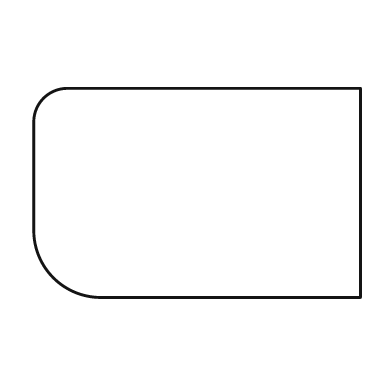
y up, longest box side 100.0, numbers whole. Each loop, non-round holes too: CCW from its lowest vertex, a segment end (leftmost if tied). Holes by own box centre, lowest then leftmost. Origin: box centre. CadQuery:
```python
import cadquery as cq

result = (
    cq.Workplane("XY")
    .moveTo(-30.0, -32.0)
    .lineTo(50.0, -32.0)
    .lineTo(50.0, 32.0)
    .lineTo(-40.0, 32.0)
    .threePointArc((-47.0, 29.0), (-50.0, 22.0))
    .lineTo(-50.0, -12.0)
    .threePointArc((-44.0, -26.0), (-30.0, -32.0))
    .close()
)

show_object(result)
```